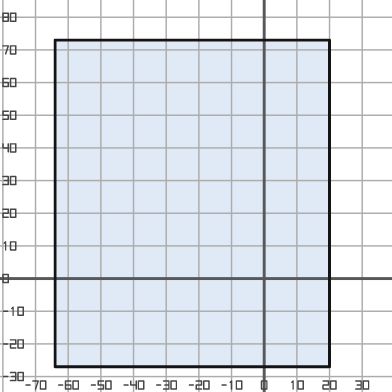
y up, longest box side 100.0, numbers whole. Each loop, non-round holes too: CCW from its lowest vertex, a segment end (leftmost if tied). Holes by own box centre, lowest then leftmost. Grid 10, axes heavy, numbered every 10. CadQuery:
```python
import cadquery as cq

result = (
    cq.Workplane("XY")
    .moveTo(-64.0, -27.0)
    .lineTo(20.0, -27.0)
    .lineTo(20.0, 73.0)
    .lineTo(-64.0, 73.0)
    .close()
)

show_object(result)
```